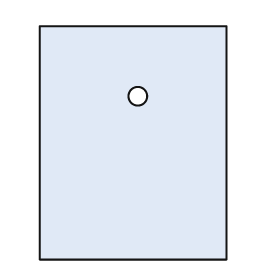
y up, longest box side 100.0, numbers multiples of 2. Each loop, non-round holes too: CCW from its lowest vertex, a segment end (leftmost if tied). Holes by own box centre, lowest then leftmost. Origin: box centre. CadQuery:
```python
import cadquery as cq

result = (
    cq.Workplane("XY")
    .moveTo(-40.0, -50.0)
    .lineTo(40.0, -50.0)
    .lineTo(40.0, 50.0)
    .lineTo(-40.0, 50.0)
    .close()
    .moveTo(2.0, 20.0)
    .circle(4.0)
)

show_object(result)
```